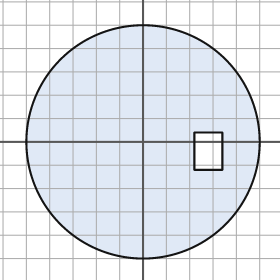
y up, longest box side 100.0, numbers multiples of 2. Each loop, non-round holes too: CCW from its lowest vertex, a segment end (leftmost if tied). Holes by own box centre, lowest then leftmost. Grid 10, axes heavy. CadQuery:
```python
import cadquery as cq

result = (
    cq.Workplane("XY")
    .moveTo(0.0, 0.0)
    .circle(50.0)
    .moveTo(22.0, -12.0)
    .lineTo(34.0, -12.0)
    .lineTo(34.0, 4.0)
    .lineTo(22.0, 4.0)
    .close()
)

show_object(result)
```